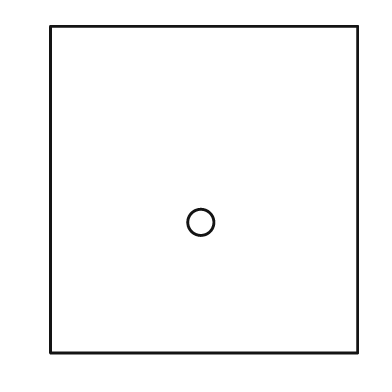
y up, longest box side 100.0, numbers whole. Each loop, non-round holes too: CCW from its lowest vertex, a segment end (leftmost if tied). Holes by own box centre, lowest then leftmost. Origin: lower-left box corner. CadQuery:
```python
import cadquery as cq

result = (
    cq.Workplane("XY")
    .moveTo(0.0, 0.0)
    .lineTo(94.0, 0.0)
    .lineTo(94.0, 100.0)
    .lineTo(0.0, 100.0)
    .close()
    .moveTo(46.0, 40.0)
    .circle(4.0)
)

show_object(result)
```